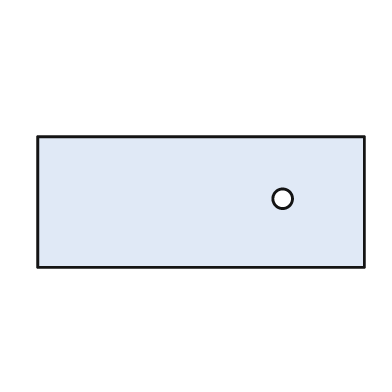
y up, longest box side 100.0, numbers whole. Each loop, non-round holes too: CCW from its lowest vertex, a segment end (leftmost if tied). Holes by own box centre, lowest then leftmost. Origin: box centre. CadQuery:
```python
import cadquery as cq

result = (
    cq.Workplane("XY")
    .moveTo(-50.0, -20.0)
    .lineTo(50.0, -20.0)
    .lineTo(50.0, 20.0)
    .lineTo(-50.0, 20.0)
    .close()
    .moveTo(25.0, 1.0)
    .circle(3.0)
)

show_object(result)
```